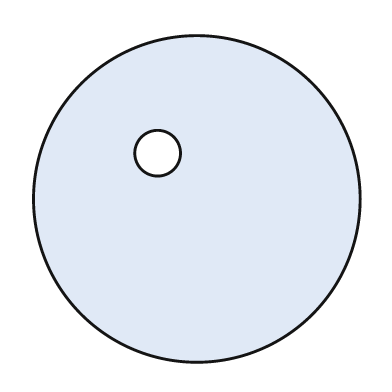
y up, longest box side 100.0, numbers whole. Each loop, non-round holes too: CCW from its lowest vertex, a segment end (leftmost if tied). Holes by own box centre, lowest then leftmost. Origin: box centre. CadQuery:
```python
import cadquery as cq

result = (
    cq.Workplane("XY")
    .moveTo(0.0, 0.0)
    .circle(50.0)
    .moveTo(-12.0, 14.0)
    .circle(7.0)
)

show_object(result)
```